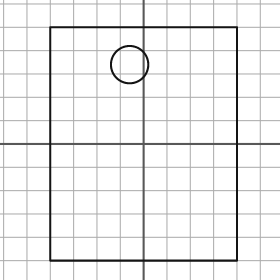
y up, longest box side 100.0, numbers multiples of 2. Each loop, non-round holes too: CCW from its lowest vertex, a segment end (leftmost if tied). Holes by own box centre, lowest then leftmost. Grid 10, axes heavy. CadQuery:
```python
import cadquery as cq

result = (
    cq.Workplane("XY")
    .moveTo(-40.0, -50.0)
    .lineTo(40.0, -50.0)
    .lineTo(40.0, 50.0)
    .lineTo(-40.0, 50.0)
    .close()
    .moveTo(-6.0, 34.0)
    .circle(8.0)
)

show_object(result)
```